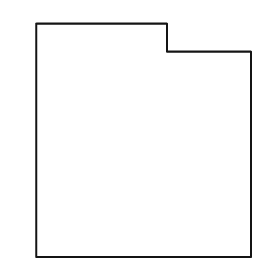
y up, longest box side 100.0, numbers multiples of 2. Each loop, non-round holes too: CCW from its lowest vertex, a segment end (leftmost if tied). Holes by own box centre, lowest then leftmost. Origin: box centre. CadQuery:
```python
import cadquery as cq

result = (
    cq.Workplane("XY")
    .moveTo(-46.0, -50.0)
    .lineTo(46.0, -50.0)
    .lineTo(46.0, 38.0)
    .lineTo(10.0, 38.0)
    .lineTo(10.0, 50.0)
    .lineTo(-46.0, 50.0)
    .close()
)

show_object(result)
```